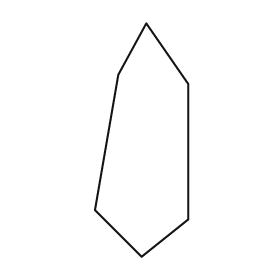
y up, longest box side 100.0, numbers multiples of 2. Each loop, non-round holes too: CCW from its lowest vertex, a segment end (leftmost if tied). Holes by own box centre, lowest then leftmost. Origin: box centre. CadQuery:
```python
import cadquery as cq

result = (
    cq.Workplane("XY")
    .moveTo(0.0, -50.0)
    .lineTo(20.0, -34.0)
    .lineTo(20.0, 24.0)
    .lineTo(2.0, 50.0)
    .lineTo(-10.0, 28.0)
    .lineTo(-20.0, -30.0)
    .close()
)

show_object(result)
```